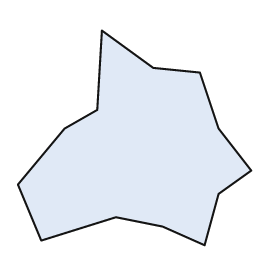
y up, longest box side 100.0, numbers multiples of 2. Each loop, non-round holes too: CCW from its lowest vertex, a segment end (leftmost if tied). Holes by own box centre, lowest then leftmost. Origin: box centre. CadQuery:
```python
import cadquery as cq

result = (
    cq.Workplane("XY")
    .moveTo(30.0, -46.0)
    .lineTo(36.0, -24.0)
    .lineTo(50.0, -14.0)
    .lineTo(36.0, 4.0)
    .lineTo(28.0, 28.0)
    .lineTo(8.0, 30.0)
    .lineTo(-14.0, 46.0)
    .lineTo(-16.0, 12.0)
    .lineTo(-30.0, 4.0)
    .lineTo(-50.0, -20.0)
    .lineTo(-40.0, -44.0)
    .lineTo(-8.0, -34.0)
    .lineTo(12.0, -38.0)
    .close()
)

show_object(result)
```